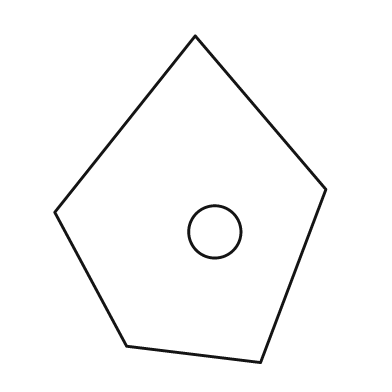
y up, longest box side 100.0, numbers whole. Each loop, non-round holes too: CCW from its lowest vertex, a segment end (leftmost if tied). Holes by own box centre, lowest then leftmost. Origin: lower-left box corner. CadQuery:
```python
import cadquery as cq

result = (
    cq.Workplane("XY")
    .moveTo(63.0, 0.0)
    .lineTo(83.0, 53.0)
    .lineTo(43.0, 100.0)
    .lineTo(0.0, 46.0)
    .lineTo(22.0, 5.0)
    .close()
    .moveTo(49.0, 40.0)
    .circle(8.0)
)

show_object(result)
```